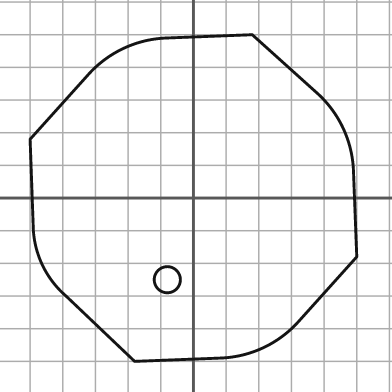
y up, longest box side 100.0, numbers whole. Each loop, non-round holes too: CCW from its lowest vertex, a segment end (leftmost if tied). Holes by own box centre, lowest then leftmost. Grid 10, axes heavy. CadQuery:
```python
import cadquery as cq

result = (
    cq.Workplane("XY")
    .moveTo(-18.0, -50.0)
    .lineTo(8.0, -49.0)
    .threePointArc((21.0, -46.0), (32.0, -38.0))
    .lineTo(50.0, -18.0)
    .lineTo(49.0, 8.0)
    .threePointArc((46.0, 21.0), (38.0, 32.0))
    .lineTo(18.0, 50.0)
    .lineTo(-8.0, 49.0)
    .threePointArc((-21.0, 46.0), (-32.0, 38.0))
    .lineTo(-50.0, 18.0)
    .lineTo(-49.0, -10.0)
    .threePointArc((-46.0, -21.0), (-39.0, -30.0))
    .close()
    .moveTo(-8.0, -25.0)
    .circle(4.0)
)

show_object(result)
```